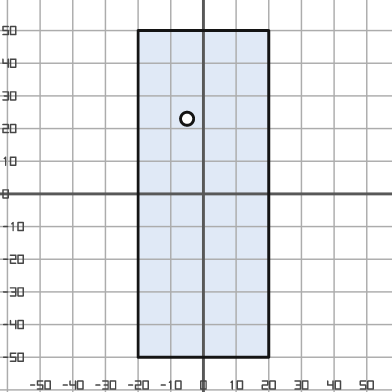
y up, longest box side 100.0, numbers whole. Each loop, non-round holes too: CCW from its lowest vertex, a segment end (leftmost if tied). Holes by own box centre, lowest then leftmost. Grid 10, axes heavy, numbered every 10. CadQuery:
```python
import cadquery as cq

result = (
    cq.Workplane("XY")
    .moveTo(-20.0, -50.0)
    .lineTo(20.0, -50.0)
    .lineTo(20.0, 50.0)
    .lineTo(-20.0, 50.0)
    .close()
    .moveTo(-5.0, 23.0)
    .circle(2.0)
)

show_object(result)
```